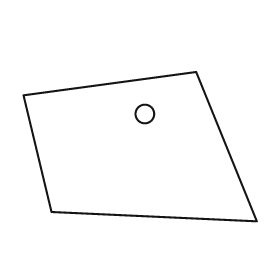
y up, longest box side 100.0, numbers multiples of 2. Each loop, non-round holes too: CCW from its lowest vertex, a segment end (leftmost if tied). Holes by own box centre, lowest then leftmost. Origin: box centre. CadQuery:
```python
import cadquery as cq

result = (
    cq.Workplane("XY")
    .moveTo(50.0, -32.0)
    .lineTo(24.0, 32.0)
    .lineTo(-50.0, 22.0)
    .lineTo(-38.0, -28.0)
    .close()
    .moveTo(2.0, 14.0)
    .circle(4.0)
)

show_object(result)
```